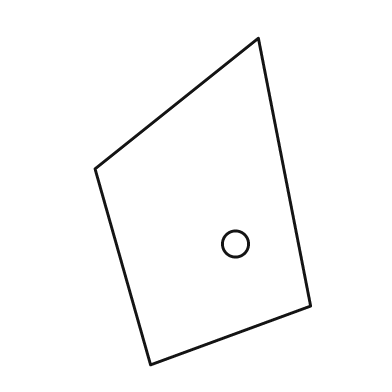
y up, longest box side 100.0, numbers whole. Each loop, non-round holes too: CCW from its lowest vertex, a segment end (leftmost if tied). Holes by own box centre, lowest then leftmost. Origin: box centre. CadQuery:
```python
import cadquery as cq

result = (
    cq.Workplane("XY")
    .moveTo(-16.0, -50.0)
    .lineTo(33.0, -32.0)
    .lineTo(17.0, 50.0)
    .lineTo(-33.0, 10.0)
    .close()
    .moveTo(10.0, -13.0)
    .circle(4.0)
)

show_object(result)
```